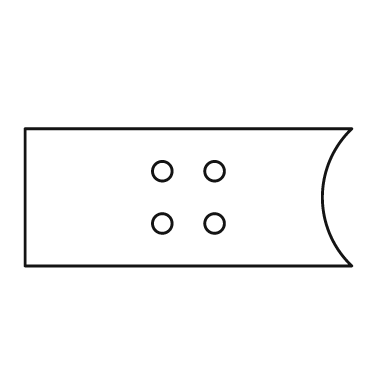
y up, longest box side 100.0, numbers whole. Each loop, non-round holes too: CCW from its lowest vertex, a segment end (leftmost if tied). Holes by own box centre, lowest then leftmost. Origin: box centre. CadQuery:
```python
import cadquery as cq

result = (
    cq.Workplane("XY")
    .moveTo(-50.0, -21.0)
    .lineTo(50.0, -21.0)
    .threePointArc((41.0, 0.0), (50.0, 21.0))
    .lineTo(-50.0, 21.0)
    .close()
    .moveTo(-8.0, -8.0)
    .circle(3.0)
    .moveTo(8.0, -8.0)
    .circle(3.0)
    .moveTo(-8.0, 8.0)
    .circle(3.0)
    .moveTo(8.0, 8.0)
    .circle(3.0)
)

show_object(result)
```